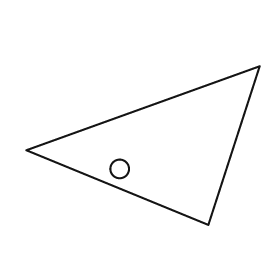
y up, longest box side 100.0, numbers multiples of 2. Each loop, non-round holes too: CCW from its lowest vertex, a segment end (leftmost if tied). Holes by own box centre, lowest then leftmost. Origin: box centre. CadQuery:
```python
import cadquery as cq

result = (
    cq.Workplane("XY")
    .moveTo(28.0, -34.0)
    .lineTo(50.0, 34.0)
    .lineTo(-50.0, -2.0)
    .close()
    .moveTo(-10.0, -10.0)
    .circle(4.0)
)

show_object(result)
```